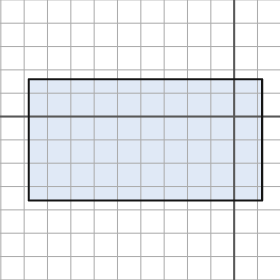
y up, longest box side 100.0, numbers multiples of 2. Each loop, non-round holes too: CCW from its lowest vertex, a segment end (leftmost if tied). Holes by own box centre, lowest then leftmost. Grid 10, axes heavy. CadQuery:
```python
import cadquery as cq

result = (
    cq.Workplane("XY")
    .moveTo(-88.0, -36.0)
    .lineTo(12.0, -36.0)
    .lineTo(12.0, 16.0)
    .lineTo(-88.0, 16.0)
    .close()
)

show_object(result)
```